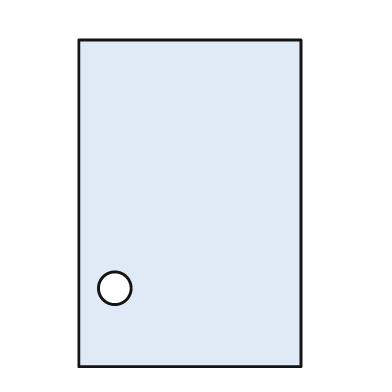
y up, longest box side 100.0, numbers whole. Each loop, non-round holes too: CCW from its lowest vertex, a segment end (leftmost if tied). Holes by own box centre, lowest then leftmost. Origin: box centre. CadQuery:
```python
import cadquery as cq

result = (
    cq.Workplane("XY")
    .moveTo(-34.0, -50.0)
    .lineTo(34.0, -50.0)
    .lineTo(34.0, 50.0)
    .lineTo(-34.0, 50.0)
    .close()
    .moveTo(-23.0, -26.0)
    .circle(5.0)
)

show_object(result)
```